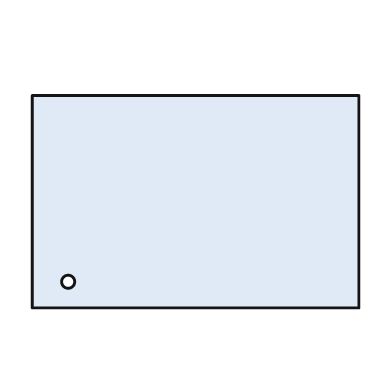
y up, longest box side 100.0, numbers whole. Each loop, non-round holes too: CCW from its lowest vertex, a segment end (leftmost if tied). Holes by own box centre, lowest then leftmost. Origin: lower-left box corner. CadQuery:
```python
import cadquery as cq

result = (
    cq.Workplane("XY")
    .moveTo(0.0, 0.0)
    .lineTo(100.0, 0.0)
    .lineTo(100.0, 65.0)
    .lineTo(0.0, 65.0)
    .close()
    .moveTo(11.0, 8.0)
    .circle(2.0)
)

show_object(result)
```